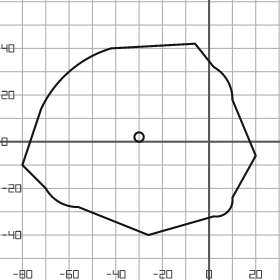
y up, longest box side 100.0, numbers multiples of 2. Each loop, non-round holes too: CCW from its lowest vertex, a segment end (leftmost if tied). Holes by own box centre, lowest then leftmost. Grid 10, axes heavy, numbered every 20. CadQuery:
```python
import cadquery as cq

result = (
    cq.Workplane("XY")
    .moveTo(-26.0, -40.0)
    .lineTo(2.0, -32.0)
    .threePointArc((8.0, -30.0), (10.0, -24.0))
    .lineTo(20.0, -6.0)
    .lineTo(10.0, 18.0)
    .threePointArc((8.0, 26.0), (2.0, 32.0))
    .lineTo(-6.0, 42.0)
    .lineTo(-42.0, 40.0)
    .threePointArc((-60.0, 30.0), (-72.0, 14.0))
    .lineTo(-80.0, -10.0)
    .lineTo(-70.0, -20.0)
    .threePointArc((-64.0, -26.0), (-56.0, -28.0))
    .close()
    .moveTo(-30.0, 2.0)
    .circle(2.0)
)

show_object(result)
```